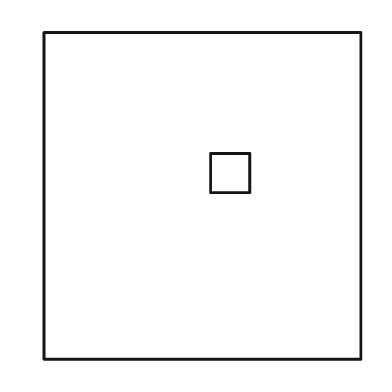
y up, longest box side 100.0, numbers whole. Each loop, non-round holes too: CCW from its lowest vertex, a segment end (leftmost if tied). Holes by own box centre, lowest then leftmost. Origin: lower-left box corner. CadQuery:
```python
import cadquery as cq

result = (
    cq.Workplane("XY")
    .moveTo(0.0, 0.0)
    .lineTo(97.0, 0.0)
    .lineTo(97.0, 100.0)
    .lineTo(0.0, 100.0)
    .close()
    .moveTo(51.0, 51.0)
    .lineTo(63.0, 51.0)
    .lineTo(63.0, 63.0)
    .lineTo(51.0, 63.0)
    .close()
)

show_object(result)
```